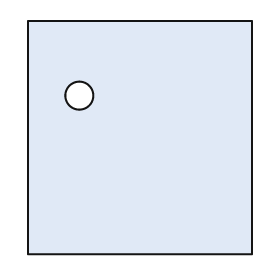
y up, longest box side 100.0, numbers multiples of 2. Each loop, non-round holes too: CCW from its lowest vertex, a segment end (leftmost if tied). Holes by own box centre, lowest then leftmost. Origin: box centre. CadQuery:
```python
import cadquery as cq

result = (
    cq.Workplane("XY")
    .moveTo(-48.0, -50.0)
    .lineTo(48.0, -50.0)
    .lineTo(48.0, 50.0)
    .lineTo(-48.0, 50.0)
    .close()
    .moveTo(-26.0, 18.0)
    .circle(6.0)
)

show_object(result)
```